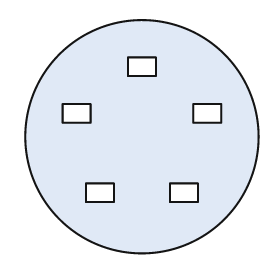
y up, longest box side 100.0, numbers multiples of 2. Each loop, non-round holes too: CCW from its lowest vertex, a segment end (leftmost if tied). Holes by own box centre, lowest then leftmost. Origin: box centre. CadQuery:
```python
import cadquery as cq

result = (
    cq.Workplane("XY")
    .moveTo(0.0, 0.0)
    .circle(50.0)
    .moveTo(-24.0, -28.0)
    .lineTo(-12.0, -28.0)
    .lineTo(-12.0, -20.0)
    .lineTo(-24.0, -20.0)
    .close()
    .moveTo(12.0, -28.0)
    .lineTo(24.0, -28.0)
    .lineTo(24.0, -20.0)
    .lineTo(12.0, -20.0)
    .close()
    .moveTo(-34.0, 6.0)
    .lineTo(-22.0, 6.0)
    .lineTo(-22.0, 14.0)
    .lineTo(-34.0, 14.0)
    .close()
    .moveTo(22.0, 6.0)
    .lineTo(34.0, 6.0)
    .lineTo(34.0, 14.0)
    .lineTo(22.0, 14.0)
    .close()
    .moveTo(-6.0, 26.0)
    .lineTo(6.0, 26.0)
    .lineTo(6.0, 34.0)
    .lineTo(-6.0, 34.0)
    .close()
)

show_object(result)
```